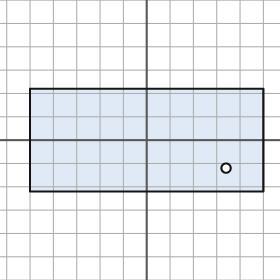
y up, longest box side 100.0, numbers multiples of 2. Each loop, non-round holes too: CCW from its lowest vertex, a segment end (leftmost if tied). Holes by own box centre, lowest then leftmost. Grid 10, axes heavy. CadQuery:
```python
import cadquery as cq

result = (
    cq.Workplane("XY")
    .moveTo(-50.0, -22.0)
    .lineTo(50.0, -22.0)
    .lineTo(50.0, 22.0)
    .lineTo(-50.0, 22.0)
    .close()
    .moveTo(34.0, -12.0)
    .circle(2.0)
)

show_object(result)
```